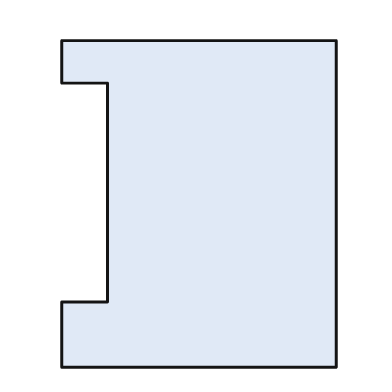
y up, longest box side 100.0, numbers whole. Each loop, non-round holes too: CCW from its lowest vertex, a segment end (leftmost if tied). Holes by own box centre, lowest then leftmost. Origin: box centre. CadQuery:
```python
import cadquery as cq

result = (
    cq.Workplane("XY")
    .moveTo(-42.0, -50.0)
    .lineTo(42.0, -50.0)
    .lineTo(42.0, 50.0)
    .lineTo(-42.0, 50.0)
    .lineTo(-42.0, 37.0)
    .lineTo(-28.0, 37.0)
    .lineTo(-28.0, -30.0)
    .lineTo(-42.0, -30.0)
    .close()
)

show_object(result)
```